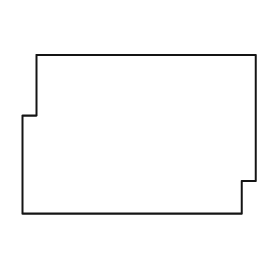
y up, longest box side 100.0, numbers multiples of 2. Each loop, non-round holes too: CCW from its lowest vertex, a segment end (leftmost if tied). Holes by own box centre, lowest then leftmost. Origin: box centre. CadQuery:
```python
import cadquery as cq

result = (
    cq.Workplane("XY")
    .moveTo(-50.0, -34.0)
    .lineTo(44.0, -34.0)
    .lineTo(44.0, -20.0)
    .lineTo(50.0, -20.0)
    .lineTo(50.0, 34.0)
    .lineTo(-44.0, 34.0)
    .lineTo(-44.0, 8.0)
    .lineTo(-50.0, 8.0)
    .close()
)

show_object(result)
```